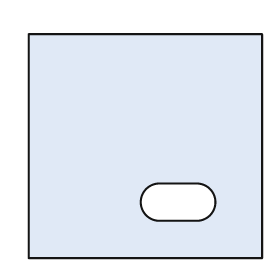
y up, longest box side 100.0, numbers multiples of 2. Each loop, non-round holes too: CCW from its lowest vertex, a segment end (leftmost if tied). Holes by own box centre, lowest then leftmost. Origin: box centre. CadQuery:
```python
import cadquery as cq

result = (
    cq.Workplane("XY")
    .moveTo(-50.0, -48.0)
    .lineTo(50.0, -48.0)
    .lineTo(50.0, 48.0)
    .lineTo(-50.0, 48.0)
    .close()
    .moveTo(6.0, -32.0)
    .lineTo(22.0, -32.0)
    .threePointArc((30.0, -24.0), (22.0, -16.0))
    .lineTo(6.0, -16.0)
    .threePointArc((-2.0, -24.0), (6.0, -32.0))
    .close()
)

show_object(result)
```